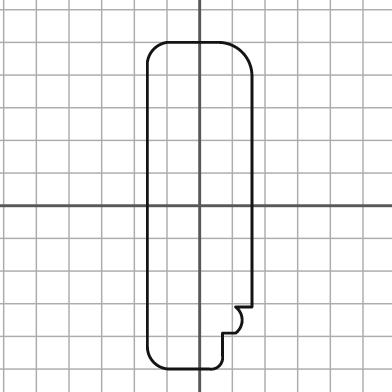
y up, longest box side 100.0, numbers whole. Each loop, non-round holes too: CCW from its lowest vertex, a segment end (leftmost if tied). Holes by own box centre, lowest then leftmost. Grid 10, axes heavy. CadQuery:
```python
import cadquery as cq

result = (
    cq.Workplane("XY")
    .moveTo(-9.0, -50.0)
    .lineTo(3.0, -50.0)
    .threePointArc((6.0, -49.0), (7.0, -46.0))
    .lineTo(7.0, -39.0)
    .lineTo(11.0, -39.0)
    .threePointArc((13.0, -35.0), (11.0, -31.0))
    .lineTo(16.0, -31.0)
    .lineTo(16.0, 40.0)
    .threePointArc((13.0, 47.0), (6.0, 50.0))
    .lineTo(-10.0, 50.0)
    .threePointArc((-14.0, 48.0), (-16.0, 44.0))
    .lineTo(-16.0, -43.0)
    .threePointArc((-14.0, -48.0), (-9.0, -50.0))
    .close()
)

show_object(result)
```